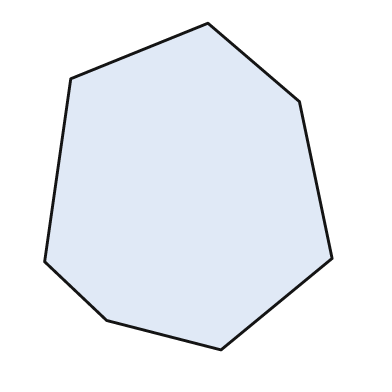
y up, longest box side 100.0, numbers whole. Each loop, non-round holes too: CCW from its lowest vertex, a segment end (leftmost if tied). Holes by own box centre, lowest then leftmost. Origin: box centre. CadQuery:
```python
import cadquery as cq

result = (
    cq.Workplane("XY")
    .moveTo(10.0, -50.0)
    .lineTo(44.0, -22.0)
    .lineTo(34.0, 26.0)
    .lineTo(6.0, 50.0)
    .lineTo(-36.0, 33.0)
    .lineTo(-44.0, -23.0)
    .lineTo(-25.0, -41.0)
    .close()
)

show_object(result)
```